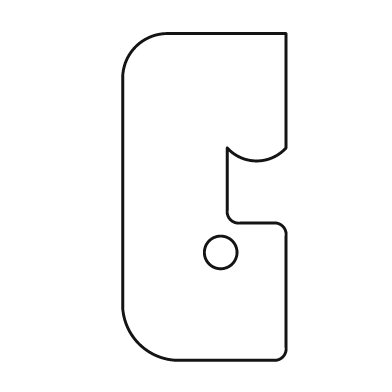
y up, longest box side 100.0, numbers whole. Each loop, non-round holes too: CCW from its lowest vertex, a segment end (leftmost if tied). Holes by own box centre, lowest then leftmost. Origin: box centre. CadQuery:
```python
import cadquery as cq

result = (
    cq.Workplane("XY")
    .moveTo(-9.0, -50.0)
    .lineTo(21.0, -50.0)
    .threePointArc((24.0, -49.0), (25.0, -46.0))
    .lineTo(25.0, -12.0)
    .threePointArc((24.0, -9.0), (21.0, -8.0))
    .lineTo(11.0, -8.0)
    .threePointArc((8.0, -7.0), (7.0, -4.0))
    .lineTo(7.0, 15.0)
    .threePointArc((16.0, 11.0), (25.0, 15.0))
    .lineTo(25.0, 50.0)
    .lineTo(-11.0, 50.0)
    .threePointArc((-21.0, 46.0), (-25.0, 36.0))
    .lineTo(-25.0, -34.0)
    .threePointArc((-20.0, -45.0), (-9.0, -50.0))
    .close()
    .moveTo(5.0, -17.0)
    .circle(5.0)
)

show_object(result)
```